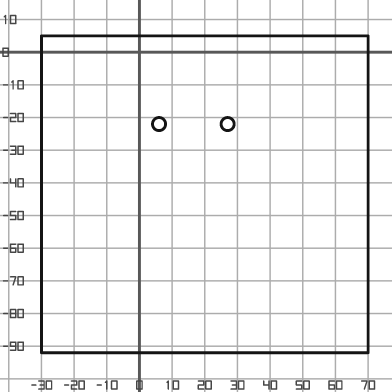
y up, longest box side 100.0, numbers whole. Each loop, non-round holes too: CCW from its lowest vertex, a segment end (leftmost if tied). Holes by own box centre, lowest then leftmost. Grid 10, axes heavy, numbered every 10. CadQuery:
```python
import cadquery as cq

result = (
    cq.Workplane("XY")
    .moveTo(-30.0, -92.0)
    .lineTo(70.0, -92.0)
    .lineTo(70.0, 5.0)
    .lineTo(-30.0, 5.0)
    .close()
    .moveTo(6.0, -22.0)
    .circle(2.0)
    .moveTo(27.0, -22.0)
    .circle(2.0)
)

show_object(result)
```